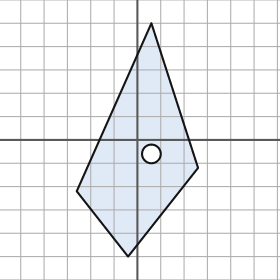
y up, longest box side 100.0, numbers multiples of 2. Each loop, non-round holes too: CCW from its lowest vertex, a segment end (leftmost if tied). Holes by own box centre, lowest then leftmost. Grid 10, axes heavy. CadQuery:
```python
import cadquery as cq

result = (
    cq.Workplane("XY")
    .moveTo(-4.0, -50.0)
    .lineTo(26.0, -12.0)
    .lineTo(6.0, 50.0)
    .lineTo(-26.0, -22.0)
    .close()
    .moveTo(6.0, -6.0)
    .circle(4.0)
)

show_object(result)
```